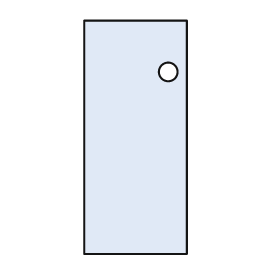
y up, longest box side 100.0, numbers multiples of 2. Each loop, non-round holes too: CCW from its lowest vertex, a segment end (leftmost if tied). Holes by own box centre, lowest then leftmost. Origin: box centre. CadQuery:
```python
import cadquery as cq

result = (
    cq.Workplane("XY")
    .moveTo(-22.0, -50.0)
    .lineTo(22.0, -50.0)
    .lineTo(22.0, 50.0)
    .lineTo(-22.0, 50.0)
    .close()
    .moveTo(14.0, 28.0)
    .circle(4.0)
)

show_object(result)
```